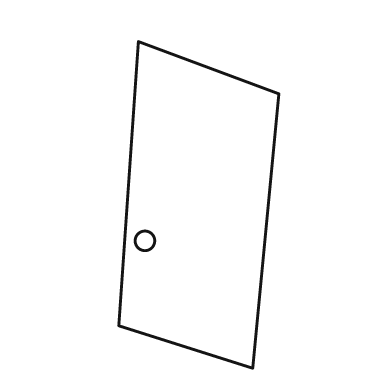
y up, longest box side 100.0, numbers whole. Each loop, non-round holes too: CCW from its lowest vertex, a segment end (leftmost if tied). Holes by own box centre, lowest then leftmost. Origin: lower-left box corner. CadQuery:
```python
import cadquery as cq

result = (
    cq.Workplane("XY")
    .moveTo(41.0, 0.0)
    .lineTo(49.0, 84.0)
    .lineTo(6.0, 100.0)
    .lineTo(0.0, 13.0)
    .close()
    .moveTo(8.0, 39.0)
    .circle(3.0)
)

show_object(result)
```